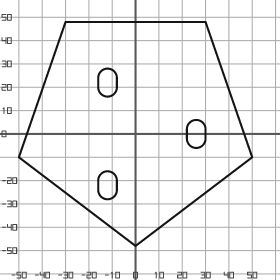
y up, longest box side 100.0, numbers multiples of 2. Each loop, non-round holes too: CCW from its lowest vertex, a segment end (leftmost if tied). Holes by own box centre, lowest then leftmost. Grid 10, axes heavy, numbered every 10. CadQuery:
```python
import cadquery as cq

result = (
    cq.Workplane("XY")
    .moveTo(0.0, -48.0)
    .lineTo(50.0, -10.0)
    .lineTo(30.0, 48.0)
    .lineTo(-30.0, 48.0)
    .lineTo(-50.0, -10.0)
    .close()
    .moveTo(-16.0, -24.0)
    .threePointArc((-12.0, -28.0), (-8.0, -24.0))
    .lineTo(-8.0, -20.0)
    .threePointArc((-12.0, -16.0), (-16.0, -20.0))
    .close()
    .moveTo(22.0, -2.0)
    .threePointArc((26.0, -6.0), (30.0, -2.0))
    .lineTo(30.0, 2.0)
    .threePointArc((26.0, 6.0), (22.0, 2.0))
    .close()
    .moveTo(-16.0, 20.0)
    .threePointArc((-12.0, 16.0), (-8.0, 20.0))
    .lineTo(-8.0, 24.0)
    .threePointArc((-12.0, 28.0), (-16.0, 24.0))
    .close()
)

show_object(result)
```